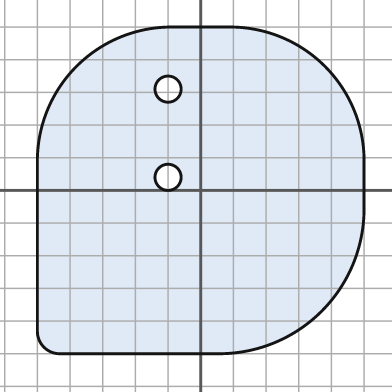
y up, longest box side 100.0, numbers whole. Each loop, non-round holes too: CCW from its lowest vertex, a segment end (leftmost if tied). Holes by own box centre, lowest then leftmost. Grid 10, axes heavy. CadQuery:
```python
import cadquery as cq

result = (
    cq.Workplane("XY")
    .moveTo(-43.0, -50.0)
    .lineTo(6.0, -50.0)
    .threePointArc((37.0, -37.0), (50.0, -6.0))
    .lineTo(50.0, 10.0)
    .threePointArc((38.0, 38.0), (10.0, 50.0))
    .lineTo(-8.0, 50.0)
    .threePointArc((-38.0, 38.0), (-50.0, 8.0))
    .lineTo(-50.0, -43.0)
    .threePointArc((-48.0, -48.0), (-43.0, -50.0))
    .close()
    .moveTo(-10.0, 4.0)
    .circle(4.0)
    .moveTo(-10.0, 31.0)
    .circle(4.0)
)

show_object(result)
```